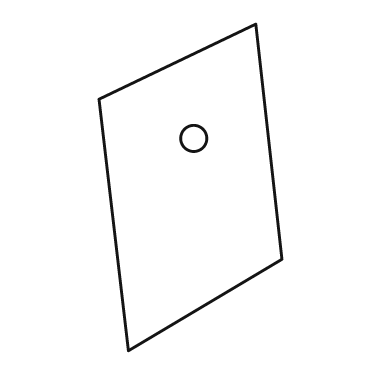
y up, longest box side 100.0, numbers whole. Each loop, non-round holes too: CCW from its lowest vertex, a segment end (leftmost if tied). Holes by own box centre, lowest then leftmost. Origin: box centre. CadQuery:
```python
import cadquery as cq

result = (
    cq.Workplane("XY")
    .moveTo(-19.0, -50.0)
    .lineTo(28.0, -22.0)
    .lineTo(20.0, 50.0)
    .lineTo(-28.0, 27.0)
    .close()
    .moveTo(1.0, 15.0)
    .circle(4.0)
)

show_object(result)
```